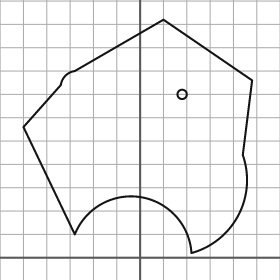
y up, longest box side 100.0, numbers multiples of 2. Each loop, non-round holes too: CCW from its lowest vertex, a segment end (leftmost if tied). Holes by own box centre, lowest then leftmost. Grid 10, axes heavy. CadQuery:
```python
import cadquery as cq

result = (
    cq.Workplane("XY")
    .moveTo(22.0, 2.0)
    .threePointArc((42.0, 18.0), (44.0, 44.0))
    .lineTo(48.0, 76.0)
    .lineTo(10.0, 102.0)
    .lineTo(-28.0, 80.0)
    .threePointArc((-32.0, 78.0), (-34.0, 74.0))
    .lineTo(-50.0, 56.0)
    .lineTo(-28.0, 10.0)
    .threePointArc((0.0, 26.0), (22.0, 2.0))
    .close()
    .moveTo(18.0, 70.0)
    .circle(2.0)
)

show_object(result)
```